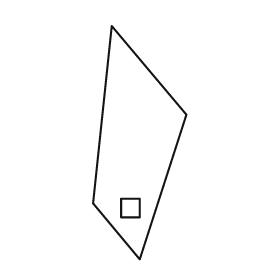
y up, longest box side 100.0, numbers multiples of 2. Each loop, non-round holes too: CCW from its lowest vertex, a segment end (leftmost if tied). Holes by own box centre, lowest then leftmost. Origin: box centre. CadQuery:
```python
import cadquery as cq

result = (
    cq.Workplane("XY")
    .moveTo(0.0, -50.0)
    .lineTo(20.0, 12.0)
    .lineTo(-12.0, 50.0)
    .lineTo(-20.0, -26.0)
    .close()
    .moveTo(-8.0, -32.0)
    .lineTo(0.0, -32.0)
    .lineTo(0.0, -24.0)
    .lineTo(-8.0, -24.0)
    .close()
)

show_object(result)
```